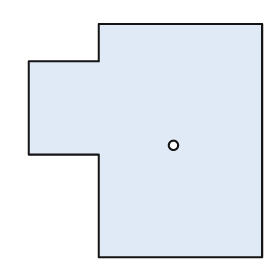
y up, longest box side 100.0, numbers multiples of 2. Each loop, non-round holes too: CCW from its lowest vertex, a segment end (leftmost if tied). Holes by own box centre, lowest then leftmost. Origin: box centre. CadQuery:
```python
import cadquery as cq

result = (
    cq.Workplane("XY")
    .moveTo(-20.0, -50.0)
    .lineTo(50.0, -50.0)
    .lineTo(50.0, 50.0)
    .lineTo(-20.0, 50.0)
    .lineTo(-20.0, 34.0)
    .lineTo(-50.0, 34.0)
    .lineTo(-50.0, -6.0)
    .lineTo(-20.0, -6.0)
    .close()
    .moveTo(12.0, -2.0)
    .circle(2.0)
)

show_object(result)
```